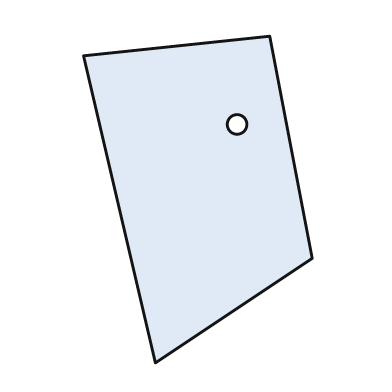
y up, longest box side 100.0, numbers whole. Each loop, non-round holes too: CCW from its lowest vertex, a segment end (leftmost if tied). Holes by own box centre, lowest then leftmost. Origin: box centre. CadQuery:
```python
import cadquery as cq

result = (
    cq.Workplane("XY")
    .moveTo(-13.0, -50.0)
    .lineTo(35.0, -18.0)
    .lineTo(22.0, 50.0)
    .lineTo(-35.0, 44.0)
    .close()
    .moveTo(12.0, 23.0)
    .circle(3.0)
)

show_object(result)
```